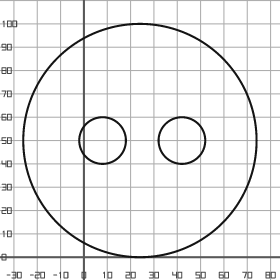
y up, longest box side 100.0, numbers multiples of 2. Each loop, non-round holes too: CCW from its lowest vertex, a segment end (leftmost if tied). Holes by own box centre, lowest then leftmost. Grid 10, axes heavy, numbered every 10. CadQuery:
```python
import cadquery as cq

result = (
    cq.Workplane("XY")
    .moveTo(24.0, 50.0)
    .circle(50.0)
    .moveTo(8.0, 50.0)
    .circle(10.0)
    .moveTo(42.0, 50.0)
    .circle(10.0)
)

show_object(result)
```